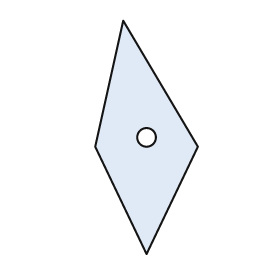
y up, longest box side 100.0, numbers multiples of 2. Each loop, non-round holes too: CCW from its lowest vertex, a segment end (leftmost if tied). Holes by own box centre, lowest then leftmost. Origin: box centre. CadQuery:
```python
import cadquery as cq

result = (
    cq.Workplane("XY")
    .moveTo(0.0, -50.0)
    .lineTo(22.0, -4.0)
    .lineTo(-10.0, 50.0)
    .lineTo(-22.0, -4.0)
    .close()
    .moveTo(0.0, 0.0)
    .circle(4.0)
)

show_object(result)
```